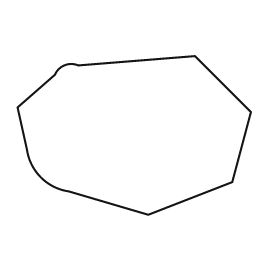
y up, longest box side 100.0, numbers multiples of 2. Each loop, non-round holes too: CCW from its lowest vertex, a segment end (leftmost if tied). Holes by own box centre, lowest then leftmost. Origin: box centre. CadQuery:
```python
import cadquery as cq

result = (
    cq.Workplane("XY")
    .moveTo(6.0, -34.0)
    .lineTo(42.0, -20.0)
    .lineTo(50.0, 10.0)
    .lineTo(26.0, 34.0)
    .lineTo(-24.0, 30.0)
    .threePointArc((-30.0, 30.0), (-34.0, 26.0))
    .lineTo(-50.0, 12.0)
    .lineTo(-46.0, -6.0)
    .threePointArc((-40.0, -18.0), (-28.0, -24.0))
    .close()
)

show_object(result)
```